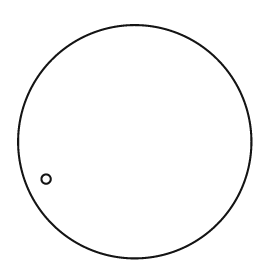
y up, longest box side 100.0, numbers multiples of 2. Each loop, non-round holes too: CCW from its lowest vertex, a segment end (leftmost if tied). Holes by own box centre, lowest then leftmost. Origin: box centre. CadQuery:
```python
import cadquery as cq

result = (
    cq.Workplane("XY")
    .moveTo(0.0, 0.0)
    .circle(50.0)
    .moveTo(-38.0, -16.0)
    .circle(2.0)
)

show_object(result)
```